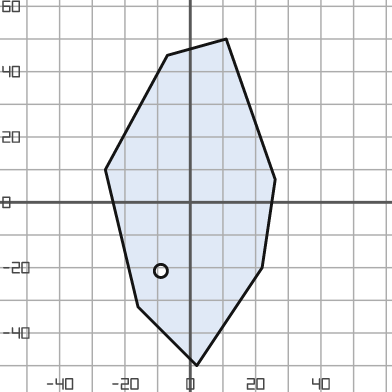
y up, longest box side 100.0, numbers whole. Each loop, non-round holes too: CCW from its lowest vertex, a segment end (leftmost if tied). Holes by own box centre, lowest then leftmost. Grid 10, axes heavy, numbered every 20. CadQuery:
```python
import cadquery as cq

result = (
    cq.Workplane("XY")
    .moveTo(2.0, -50.0)
    .lineTo(22.0, -20.0)
    .lineTo(26.0, 7.0)
    .lineTo(11.0, 50.0)
    .lineTo(-7.0, 45.0)
    .lineTo(-26.0, 10.0)
    .lineTo(-16.0, -32.0)
    .close()
    .moveTo(-9.0, -21.0)
    .circle(2.0)
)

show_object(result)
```